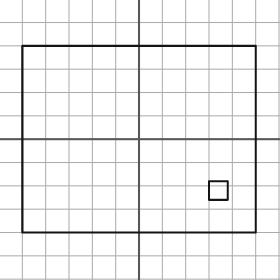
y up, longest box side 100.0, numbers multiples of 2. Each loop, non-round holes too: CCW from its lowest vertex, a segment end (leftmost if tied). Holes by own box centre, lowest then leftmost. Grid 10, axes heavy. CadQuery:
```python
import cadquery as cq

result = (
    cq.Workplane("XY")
    .moveTo(-50.0, -40.0)
    .lineTo(50.0, -40.0)
    .lineTo(50.0, 40.0)
    .lineTo(-50.0, 40.0)
    .close()
    .moveTo(30.0, -26.0)
    .lineTo(38.0, -26.0)
    .lineTo(38.0, -18.0)
    .lineTo(30.0, -18.0)
    .close()
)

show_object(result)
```